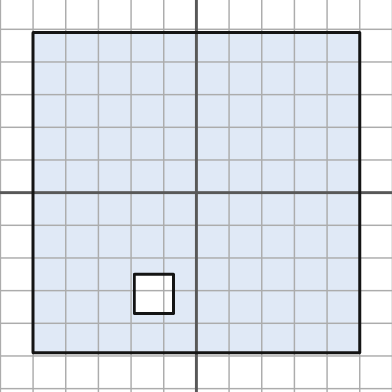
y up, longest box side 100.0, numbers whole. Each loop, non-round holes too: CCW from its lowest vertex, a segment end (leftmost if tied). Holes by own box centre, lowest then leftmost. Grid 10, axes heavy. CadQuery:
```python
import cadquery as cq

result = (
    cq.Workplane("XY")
    .moveTo(-50.0, -49.0)
    .lineTo(50.0, -49.0)
    .lineTo(50.0, 49.0)
    .lineTo(-50.0, 49.0)
    .close()
    .moveTo(-19.0, -37.0)
    .lineTo(-7.0, -37.0)
    .lineTo(-7.0, -25.0)
    .lineTo(-19.0, -25.0)
    .close()
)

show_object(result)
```